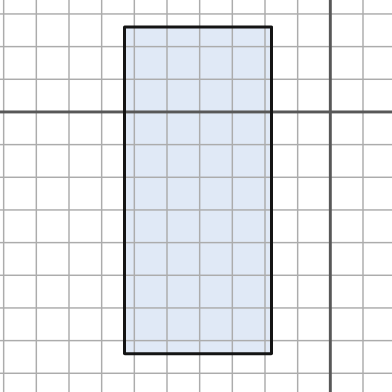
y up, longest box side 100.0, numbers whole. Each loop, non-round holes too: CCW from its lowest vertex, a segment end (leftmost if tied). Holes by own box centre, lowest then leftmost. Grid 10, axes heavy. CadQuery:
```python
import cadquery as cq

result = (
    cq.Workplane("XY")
    .moveTo(-63.0, -74.0)
    .lineTo(-18.0, -74.0)
    .lineTo(-18.0, 26.0)
    .lineTo(-63.0, 26.0)
    .close()
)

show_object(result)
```